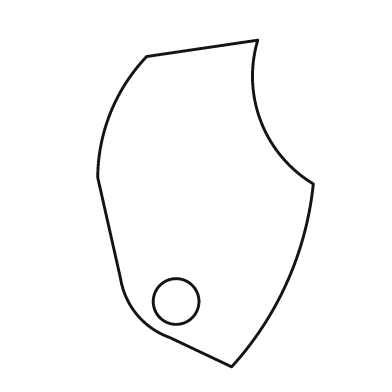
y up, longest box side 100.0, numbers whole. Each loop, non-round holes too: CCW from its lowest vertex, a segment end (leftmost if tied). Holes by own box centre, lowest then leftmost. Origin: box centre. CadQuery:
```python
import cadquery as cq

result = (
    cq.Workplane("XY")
    .moveTo(8.0, -50.0)
    .threePointArc((25.0, -24.0), (33.0, 6.0))
    .threePointArc((17.0, 25.0), (16.0, 50.0))
    .lineTo(-18.0, 45.0)
    .threePointArc((-29.0, 28.0), (-33.0, 8.0))
    .lineTo(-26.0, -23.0)
    .threePointArc((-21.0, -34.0), (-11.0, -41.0))
    .close()
    .moveTo(-9.0, -30.0)
    .circle(7.0)
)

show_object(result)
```